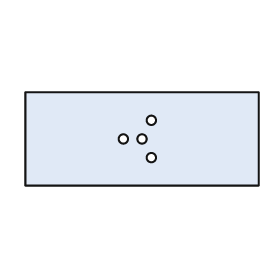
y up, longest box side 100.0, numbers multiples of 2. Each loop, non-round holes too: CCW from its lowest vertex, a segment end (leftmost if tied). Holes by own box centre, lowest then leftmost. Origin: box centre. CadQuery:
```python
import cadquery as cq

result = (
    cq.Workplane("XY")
    .moveTo(-50.0, -20.0)
    .lineTo(50.0, -20.0)
    .lineTo(50.0, 20.0)
    .lineTo(-50.0, 20.0)
    .close()
    .moveTo(4.0, -8.0)
    .circle(2.0)
    .moveTo(-8.0, 0.0)
    .circle(2.0)
    .moveTo(0.0, 0.0)
    .circle(2.0)
    .moveTo(4.0, 8.0)
    .circle(2.0)
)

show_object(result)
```